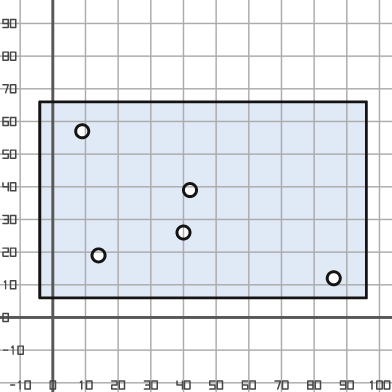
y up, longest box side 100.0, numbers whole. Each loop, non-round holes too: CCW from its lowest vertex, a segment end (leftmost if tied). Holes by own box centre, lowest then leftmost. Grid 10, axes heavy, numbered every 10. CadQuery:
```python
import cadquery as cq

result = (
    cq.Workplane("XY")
    .moveTo(-4.0, 6.0)
    .lineTo(96.0, 6.0)
    .lineTo(96.0, 66.0)
    .lineTo(-4.0, 66.0)
    .close()
    .moveTo(86.0, 12.0)
    .circle(2.0)
    .moveTo(14.0, 19.0)
    .circle(2.0)
    .moveTo(40.0, 26.0)
    .circle(2.0)
    .moveTo(42.0, 39.0)
    .circle(2.0)
    .moveTo(9.0, 57.0)
    .circle(2.0)
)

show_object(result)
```